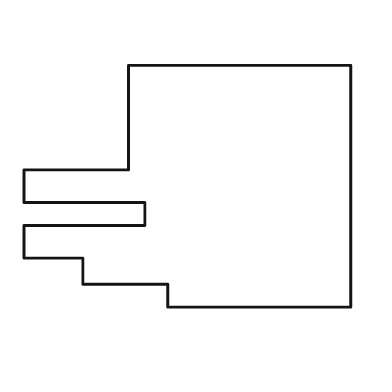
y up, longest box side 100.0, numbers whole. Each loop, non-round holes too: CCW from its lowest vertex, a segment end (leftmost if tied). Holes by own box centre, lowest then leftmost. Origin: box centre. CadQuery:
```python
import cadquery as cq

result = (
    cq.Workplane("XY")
    .moveTo(-6.0, -37.0)
    .lineTo(50.0, -37.0)
    .lineTo(50.0, 37.0)
    .lineTo(-18.0, 37.0)
    .lineTo(-18.0, 5.0)
    .lineTo(-50.0, 5.0)
    .lineTo(-50.0, -5.0)
    .lineTo(-13.0, -5.0)
    .lineTo(-13.0, -12.0)
    .lineTo(-50.0, -12.0)
    .lineTo(-50.0, -22.0)
    .lineTo(-32.0, -22.0)
    .lineTo(-32.0, -30.0)
    .lineTo(-6.0, -30.0)
    .close()
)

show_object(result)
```